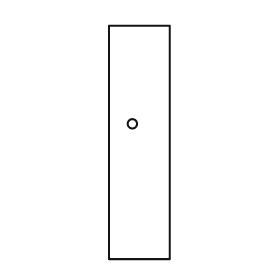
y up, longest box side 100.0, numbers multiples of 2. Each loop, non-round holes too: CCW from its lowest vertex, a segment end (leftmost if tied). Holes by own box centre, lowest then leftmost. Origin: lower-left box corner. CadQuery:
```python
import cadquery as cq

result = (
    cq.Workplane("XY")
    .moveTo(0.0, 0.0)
    .lineTo(26.0, 0.0)
    .lineTo(26.0, 100.0)
    .lineTo(0.0, 100.0)
    .close()
    .moveTo(10.0, 58.0)
    .circle(2.0)
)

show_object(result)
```